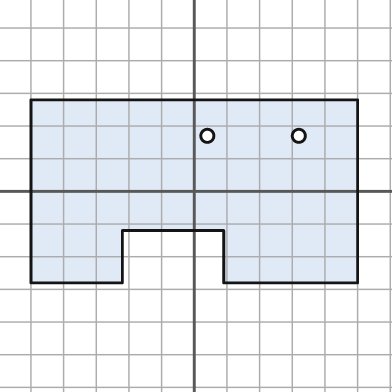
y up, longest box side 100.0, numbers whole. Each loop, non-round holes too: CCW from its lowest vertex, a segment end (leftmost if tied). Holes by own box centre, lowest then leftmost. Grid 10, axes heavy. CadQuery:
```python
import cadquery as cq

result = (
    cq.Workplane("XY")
    .moveTo(-50.0, -28.0)
    .lineTo(-22.0, -28.0)
    .lineTo(-22.0, -12.0)
    .lineTo(9.0, -12.0)
    .lineTo(9.0, -28.0)
    .lineTo(50.0, -28.0)
    .lineTo(50.0, 28.0)
    .lineTo(-50.0, 28.0)
    .close()
    .moveTo(4.0, 17.0)
    .circle(2.0)
    .moveTo(32.0, 17.0)
    .circle(2.0)
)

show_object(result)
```